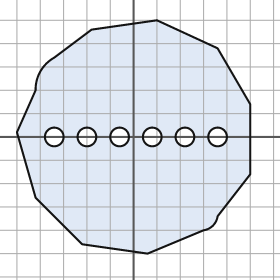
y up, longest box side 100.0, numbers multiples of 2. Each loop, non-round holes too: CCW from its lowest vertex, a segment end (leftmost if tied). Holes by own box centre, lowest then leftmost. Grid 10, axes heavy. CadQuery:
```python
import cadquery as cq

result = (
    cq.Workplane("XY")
    .moveTo(6.0, -50.0)
    .lineTo(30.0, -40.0)
    .threePointArc((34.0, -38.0), (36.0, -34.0))
    .lineTo(50.0, -16.0)
    .lineTo(50.0, 14.0)
    .lineTo(36.0, 38.0)
    .lineTo(10.0, 50.0)
    .lineTo(-18.0, 46.0)
    .lineTo(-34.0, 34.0)
    .threePointArc((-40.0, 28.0), (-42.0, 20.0))
    .lineTo(-50.0, 2.0)
    .lineTo(-42.0, -26.0)
    .lineTo(-22.0, -46.0)
    .close()
    .moveTo(-34.0, 0.0)
    .circle(4.0)
    .moveTo(-20.0, 0.0)
    .circle(4.0)
    .moveTo(-6.0, 0.0)
    .circle(4.0)
    .moveTo(8.0, 0.0)
    .circle(4.0)
    .moveTo(22.0, 0.0)
    .circle(4.0)
    .moveTo(36.0, 0.0)
    .circle(4.0)
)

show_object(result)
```